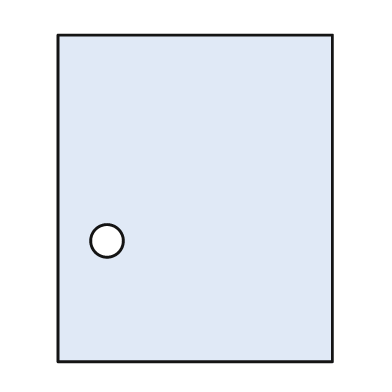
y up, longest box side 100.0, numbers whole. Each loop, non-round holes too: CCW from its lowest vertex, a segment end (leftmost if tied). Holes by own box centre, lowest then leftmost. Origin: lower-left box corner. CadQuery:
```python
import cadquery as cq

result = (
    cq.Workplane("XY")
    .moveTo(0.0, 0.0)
    .lineTo(84.0, 0.0)
    .lineTo(84.0, 100.0)
    .lineTo(0.0, 100.0)
    .close()
    .moveTo(15.0, 37.0)
    .circle(5.0)
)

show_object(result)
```